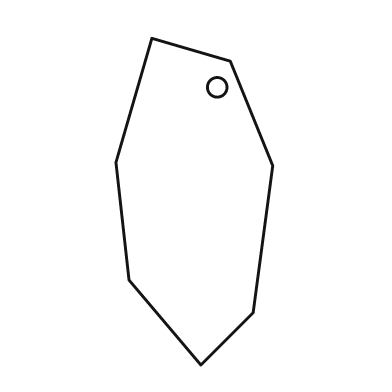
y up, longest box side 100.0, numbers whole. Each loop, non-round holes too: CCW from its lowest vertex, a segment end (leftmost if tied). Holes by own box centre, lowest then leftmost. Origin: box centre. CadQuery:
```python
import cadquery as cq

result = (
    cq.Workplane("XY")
    .moveTo(2.0, -50.0)
    .lineTo(18.0, -34.0)
    .lineTo(24.0, 11.0)
    .lineTo(11.0, 43.0)
    .lineTo(-13.0, 50.0)
    .lineTo(-24.0, 12.0)
    .lineTo(-20.0, -24.0)
    .close()
    .moveTo(7.0, 35.0)
    .circle(3.0)
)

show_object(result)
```